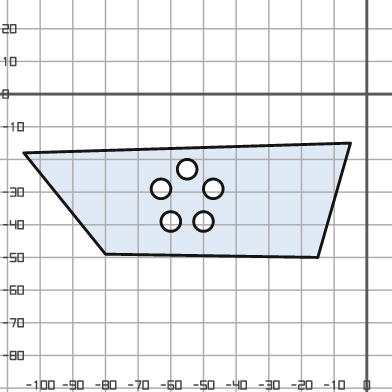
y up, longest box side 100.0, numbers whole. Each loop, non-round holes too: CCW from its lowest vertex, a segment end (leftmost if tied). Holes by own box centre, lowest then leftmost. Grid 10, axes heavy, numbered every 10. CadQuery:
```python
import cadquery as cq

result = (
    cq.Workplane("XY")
    .moveTo(-15.0, -50.0)
    .lineTo(-5.0, -15.0)
    .lineTo(-105.0, -18.0)
    .lineTo(-80.0, -49.0)
    .close()
    .moveTo(-60.0, -39.0)
    .circle(3.0)
    .moveTo(-50.0, -39.0)
    .circle(3.0)
    .moveTo(-63.0, -29.0)
    .circle(3.0)
    .moveTo(-47.0, -29.0)
    .circle(3.0)
    .moveTo(-55.0, -23.0)
    .circle(3.0)
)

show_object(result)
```